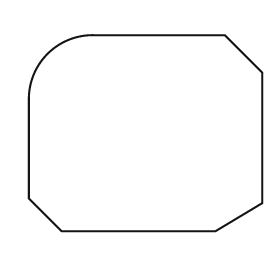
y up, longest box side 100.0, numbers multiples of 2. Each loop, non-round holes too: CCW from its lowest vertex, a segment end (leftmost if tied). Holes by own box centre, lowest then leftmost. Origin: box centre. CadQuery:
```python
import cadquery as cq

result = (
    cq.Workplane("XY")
    .moveTo(-36.0, -42.0)
    .lineTo(30.0, -42.0)
    .lineTo(50.0, -30.0)
    .lineTo(50.0, 26.0)
    .lineTo(34.0, 42.0)
    .lineTo(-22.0, 42.0)
    .threePointArc((-42.0, 34.0), (-50.0, 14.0))
    .lineTo(-50.0, -28.0)
    .close()
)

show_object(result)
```